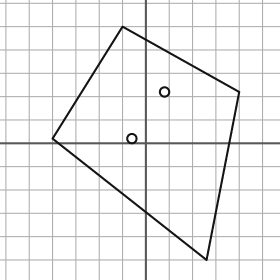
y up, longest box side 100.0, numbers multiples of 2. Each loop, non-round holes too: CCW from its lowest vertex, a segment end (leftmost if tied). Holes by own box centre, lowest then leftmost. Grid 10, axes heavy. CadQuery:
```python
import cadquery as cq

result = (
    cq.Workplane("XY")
    .moveTo(26.0, -50.0)
    .lineTo(40.0, 22.0)
    .lineTo(-10.0, 50.0)
    .lineTo(-40.0, 2.0)
    .close()
    .moveTo(-6.0, 2.0)
    .circle(2.0)
    .moveTo(8.0, 22.0)
    .circle(2.0)
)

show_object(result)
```